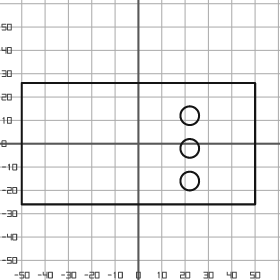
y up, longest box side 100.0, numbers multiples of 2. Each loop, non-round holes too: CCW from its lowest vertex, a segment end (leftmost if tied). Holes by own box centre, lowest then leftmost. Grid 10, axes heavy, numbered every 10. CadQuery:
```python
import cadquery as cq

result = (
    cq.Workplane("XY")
    .moveTo(-50.0, -26.0)
    .lineTo(50.0, -26.0)
    .lineTo(50.0, 26.0)
    .lineTo(-50.0, 26.0)
    .close()
    .moveTo(22.0, -16.0)
    .circle(4.0)
    .moveTo(22.0, -2.0)
    .circle(4.0)
    .moveTo(22.0, 12.0)
    .circle(4.0)
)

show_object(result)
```